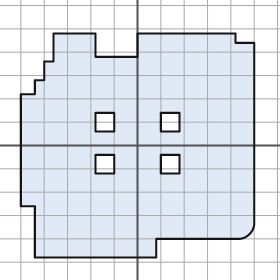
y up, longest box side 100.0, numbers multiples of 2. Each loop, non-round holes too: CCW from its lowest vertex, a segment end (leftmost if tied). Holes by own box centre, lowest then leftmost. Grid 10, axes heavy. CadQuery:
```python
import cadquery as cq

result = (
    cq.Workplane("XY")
    .moveTo(-44.0, -48.0)
    .lineTo(8.0, -48.0)
    .lineTo(8.0, -40.0)
    .lineTo(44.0, -40.0)
    .threePointArc((48.0, -38.0), (50.0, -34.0))
    .lineTo(50.0, 44.0)
    .lineTo(42.0, 44.0)
    .lineTo(42.0, 48.0)
    .lineTo(0.0, 48.0)
    .lineTo(0.0, 38.0)
    .lineTo(-18.0, 38.0)
    .lineTo(-18.0, 48.0)
    .lineTo(-36.0, 48.0)
    .lineTo(-36.0, 36.0)
    .lineTo(-40.0, 36.0)
    .lineTo(-40.0, 28.0)
    .lineTo(-44.0, 28.0)
    .lineTo(-44.0, 22.0)
    .lineTo(-50.0, 22.0)
    .lineTo(-50.0, -26.0)
    .lineTo(-44.0, -26.0)
    .close()
    .moveTo(-18.0, -12.0)
    .lineTo(-10.0, -12.0)
    .lineTo(-10.0, -4.0)
    .lineTo(-18.0, -4.0)
    .close()
    .moveTo(10.0, -12.0)
    .lineTo(18.0, -12.0)
    .lineTo(18.0, -4.0)
    .lineTo(10.0, -4.0)
    .close()
    .moveTo(-18.0, 6.0)
    .lineTo(-10.0, 6.0)
    .lineTo(-10.0, 14.0)
    .lineTo(-18.0, 14.0)
    .close()
    .moveTo(10.0, 6.0)
    .lineTo(18.0, 6.0)
    .lineTo(18.0, 14.0)
    .lineTo(10.0, 14.0)
    .close()
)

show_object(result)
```